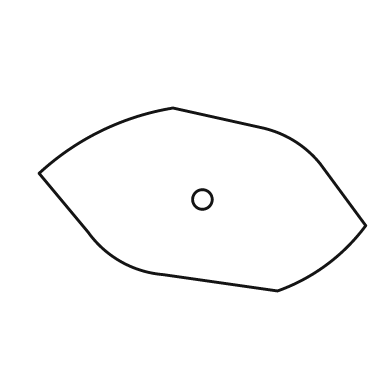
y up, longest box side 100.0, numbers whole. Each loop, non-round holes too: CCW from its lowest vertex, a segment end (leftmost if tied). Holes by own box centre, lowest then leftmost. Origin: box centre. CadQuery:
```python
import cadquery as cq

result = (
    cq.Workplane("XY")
    .moveTo(23.0, -28.0)
    .threePointArc((38.0, -20.0), (50.0, -8.0))
    .lineTo(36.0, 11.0)
    .threePointArc((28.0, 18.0), (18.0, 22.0))
    .lineTo(-9.0, 28.0)
    .threePointArc((-31.0, 21.0), (-50.0, 8.0))
    .lineTo(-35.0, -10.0)
    .threePointArc((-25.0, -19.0), (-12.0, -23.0))
    .close()
    .moveTo(0.0, 0.0)
    .circle(3.0)
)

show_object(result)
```